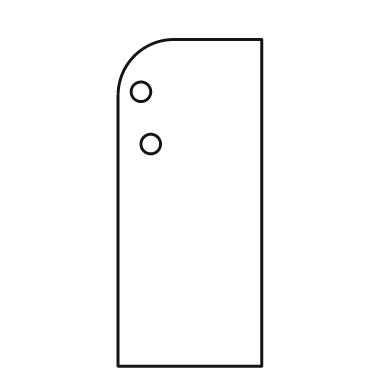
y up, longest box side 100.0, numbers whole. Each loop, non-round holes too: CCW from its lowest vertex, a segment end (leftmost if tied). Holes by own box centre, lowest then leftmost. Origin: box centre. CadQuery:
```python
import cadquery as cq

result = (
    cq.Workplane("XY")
    .moveTo(-22.0, -50.0)
    .lineTo(22.0, -50.0)
    .lineTo(22.0, 50.0)
    .lineTo(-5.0, 50.0)
    .threePointArc((-17.0, 45.0), (-22.0, 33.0))
    .close()
    .moveTo(-12.0, 18.0)
    .circle(3.0)
    .moveTo(-15.0, 34.0)
    .circle(3.0)
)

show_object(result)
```